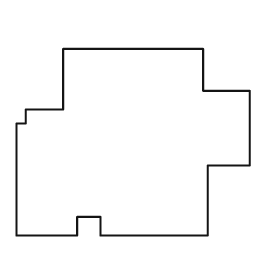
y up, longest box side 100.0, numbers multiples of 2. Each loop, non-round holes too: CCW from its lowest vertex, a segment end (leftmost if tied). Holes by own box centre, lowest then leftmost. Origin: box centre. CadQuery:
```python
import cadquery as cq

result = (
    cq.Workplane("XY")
    .moveTo(-50.0, -40.0)
    .lineTo(-24.0, -40.0)
    .lineTo(-24.0, -32.0)
    .lineTo(-14.0, -32.0)
    .lineTo(-14.0, -40.0)
    .lineTo(32.0, -40.0)
    .lineTo(32.0, -10.0)
    .lineTo(50.0, -10.0)
    .lineTo(50.0, 22.0)
    .lineTo(30.0, 22.0)
    .lineTo(30.0, 40.0)
    .lineTo(-30.0, 40.0)
    .lineTo(-30.0, 14.0)
    .lineTo(-46.0, 14.0)
    .lineTo(-46.0, 8.0)
    .lineTo(-50.0, 8.0)
    .close()
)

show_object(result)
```